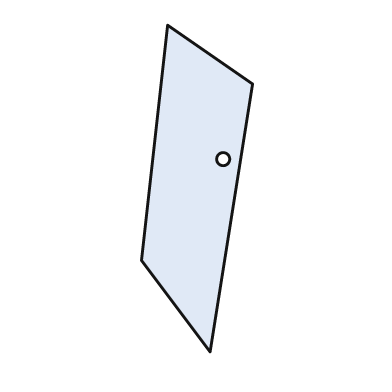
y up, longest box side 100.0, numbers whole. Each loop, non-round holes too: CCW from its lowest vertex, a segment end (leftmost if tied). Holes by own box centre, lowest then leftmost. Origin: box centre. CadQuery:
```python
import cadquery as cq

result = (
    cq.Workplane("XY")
    .moveTo(4.0, -50.0)
    .lineTo(17.0, 32.0)
    .lineTo(-9.0, 50.0)
    .lineTo(-17.0, -22.0)
    .close()
    .moveTo(8.0, 9.0)
    .circle(2.0)
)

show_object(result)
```